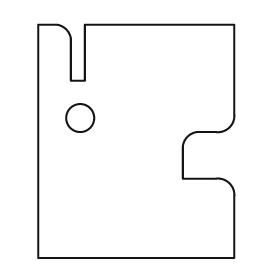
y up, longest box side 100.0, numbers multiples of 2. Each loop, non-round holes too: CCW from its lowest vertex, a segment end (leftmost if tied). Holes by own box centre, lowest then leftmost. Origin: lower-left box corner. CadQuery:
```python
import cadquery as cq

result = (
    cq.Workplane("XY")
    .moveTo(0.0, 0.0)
    .lineTo(84.0, 0.0)
    .lineTo(84.0, 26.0)
    .threePointArc((82.0, 32.0), (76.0, 34.0))
    .lineTo(62.0, 34.0)
    .lineTo(62.0, 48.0)
    .threePointArc((64.0, 52.0), (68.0, 54.0))
    .lineTo(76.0, 54.0)
    .threePointArc((82.0, 56.0), (84.0, 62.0))
    .lineTo(84.0, 100.0)
    .lineTo(20.0, 100.0)
    .lineTo(20.0, 76.0)
    .lineTo(14.0, 76.0)
    .lineTo(14.0, 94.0)
    .threePointArc((12.0, 98.0), (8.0, 100.0))
    .lineTo(0.0, 100.0)
    .close()
    .moveTo(18.0, 60.0)
    .circle(6.0)
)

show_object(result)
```